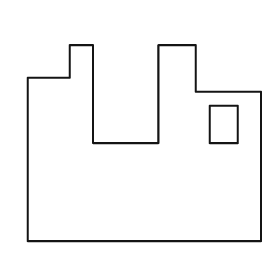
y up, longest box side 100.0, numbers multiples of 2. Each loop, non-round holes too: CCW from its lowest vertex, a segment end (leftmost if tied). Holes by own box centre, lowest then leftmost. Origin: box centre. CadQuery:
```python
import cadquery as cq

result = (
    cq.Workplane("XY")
    .moveTo(-50.0, -42.0)
    .lineTo(50.0, -42.0)
    .lineTo(50.0, 22.0)
    .lineTo(22.0, 22.0)
    .lineTo(22.0, 42.0)
    .lineTo(6.0, 42.0)
    .lineTo(6.0, 0.0)
    .lineTo(-22.0, 0.0)
    .lineTo(-22.0, 42.0)
    .lineTo(-32.0, 42.0)
    .lineTo(-32.0, 28.0)
    .lineTo(-50.0, 28.0)
    .close()
    .moveTo(28.0, 0.0)
    .lineTo(40.0, 0.0)
    .lineTo(40.0, 16.0)
    .lineTo(28.0, 16.0)
    .close()
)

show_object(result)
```